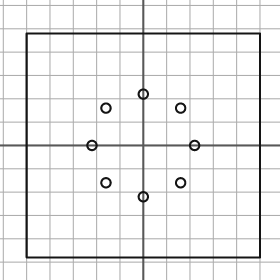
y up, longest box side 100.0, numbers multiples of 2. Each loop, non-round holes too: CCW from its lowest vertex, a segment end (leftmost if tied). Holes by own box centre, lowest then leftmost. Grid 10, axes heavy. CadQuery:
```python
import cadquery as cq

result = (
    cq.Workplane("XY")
    .moveTo(-50.0, -48.0)
    .lineTo(50.0, -48.0)
    .lineTo(50.0, 48.0)
    .lineTo(-50.0, 48.0)
    .close()
    .moveTo(0.0, -22.0)
    .circle(2.0)
    .moveTo(-16.0, -16.0)
    .circle(2.0)
    .moveTo(16.0, -16.0)
    .circle(2.0)
    .moveTo(-22.0, 0.0)
    .circle(2.0)
    .moveTo(22.0, 0.0)
    .circle(2.0)
    .moveTo(-16.0, 16.0)
    .circle(2.0)
    .moveTo(16.0, 16.0)
    .circle(2.0)
    .moveTo(0.0, 22.0)
    .circle(2.0)
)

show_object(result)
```